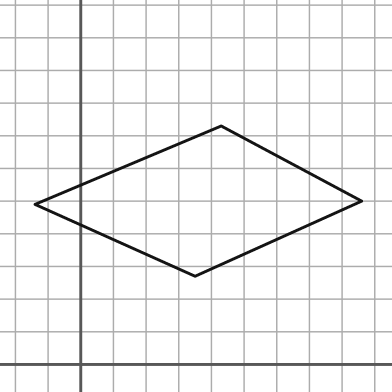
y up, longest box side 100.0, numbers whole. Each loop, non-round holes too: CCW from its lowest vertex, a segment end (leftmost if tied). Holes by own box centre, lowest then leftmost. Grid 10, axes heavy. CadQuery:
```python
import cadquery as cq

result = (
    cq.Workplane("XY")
    .moveTo(35.0, 27.0)
    .lineTo(86.0, 50.0)
    .lineTo(43.0, 73.0)
    .lineTo(-14.0, 49.0)
    .close()
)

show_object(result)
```